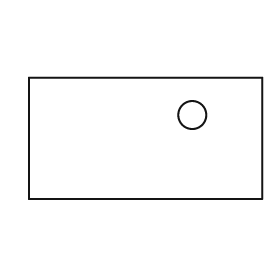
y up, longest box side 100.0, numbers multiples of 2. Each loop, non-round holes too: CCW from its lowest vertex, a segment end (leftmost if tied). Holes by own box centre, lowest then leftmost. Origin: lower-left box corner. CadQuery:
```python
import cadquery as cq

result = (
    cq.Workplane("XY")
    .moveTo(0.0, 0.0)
    .lineTo(100.0, 0.0)
    .lineTo(100.0, 52.0)
    .lineTo(0.0, 52.0)
    .close()
    .moveTo(70.0, 36.0)
    .circle(6.0)
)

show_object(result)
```